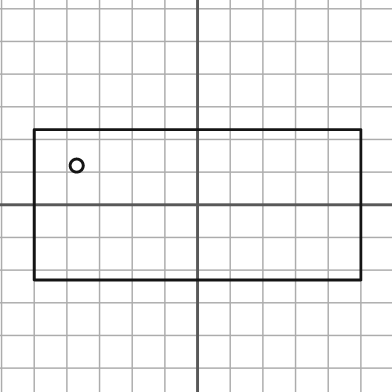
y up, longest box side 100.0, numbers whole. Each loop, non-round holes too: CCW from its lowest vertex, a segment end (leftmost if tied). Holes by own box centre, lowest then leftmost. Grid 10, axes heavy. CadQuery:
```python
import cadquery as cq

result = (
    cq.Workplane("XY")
    .moveTo(-50.0, -23.0)
    .lineTo(50.0, -23.0)
    .lineTo(50.0, 23.0)
    .lineTo(-50.0, 23.0)
    .close()
    .moveTo(-37.0, 12.0)
    .circle(2.0)
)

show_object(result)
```